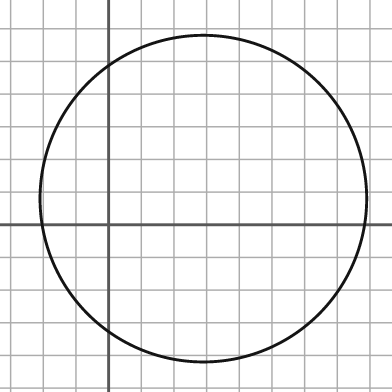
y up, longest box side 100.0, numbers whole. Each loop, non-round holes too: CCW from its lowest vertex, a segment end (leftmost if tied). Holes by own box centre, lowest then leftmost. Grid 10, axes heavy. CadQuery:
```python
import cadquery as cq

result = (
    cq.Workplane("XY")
    .moveTo(29.0, 8.0)
    .circle(50.0)
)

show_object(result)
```